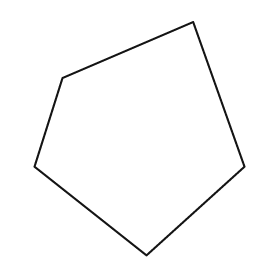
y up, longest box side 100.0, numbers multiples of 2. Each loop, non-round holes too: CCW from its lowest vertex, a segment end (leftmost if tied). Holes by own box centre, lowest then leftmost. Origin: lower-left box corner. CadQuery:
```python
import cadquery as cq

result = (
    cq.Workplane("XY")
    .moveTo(48.0, 0.0)
    .lineTo(90.0, 38.0)
    .lineTo(68.0, 100.0)
    .lineTo(12.0, 76.0)
    .lineTo(0.0, 38.0)
    .close()
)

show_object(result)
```